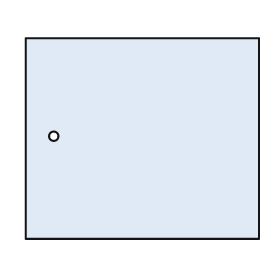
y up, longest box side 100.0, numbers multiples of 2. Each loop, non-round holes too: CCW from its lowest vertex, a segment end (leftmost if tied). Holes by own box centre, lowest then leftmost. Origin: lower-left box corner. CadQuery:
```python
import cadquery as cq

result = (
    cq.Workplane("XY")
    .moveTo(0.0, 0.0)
    .lineTo(100.0, 0.0)
    .lineTo(100.0, 86.0)
    .lineTo(0.0, 86.0)
    .close()
    .moveTo(12.0, 44.0)
    .circle(2.0)
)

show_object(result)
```